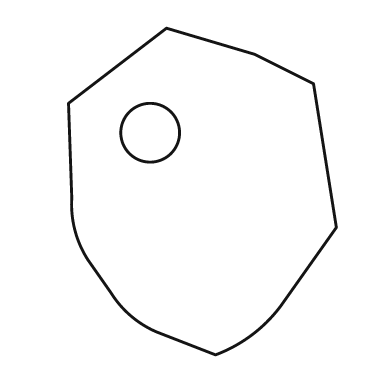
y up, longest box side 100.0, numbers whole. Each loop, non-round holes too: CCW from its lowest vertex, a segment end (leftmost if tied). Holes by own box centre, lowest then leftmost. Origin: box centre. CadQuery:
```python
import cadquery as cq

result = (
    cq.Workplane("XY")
    .moveTo(4.0, -50.0)
    .threePointArc((15.0, -44.0), (24.0, -35.0))
    .lineTo(41.0, -11.0)
    .lineTo(34.0, 33.0)
    .lineTo(16.0, 42.0)
    .lineTo(-11.0, 50.0)
    .lineTo(-41.0, 27.0)
    .lineTo(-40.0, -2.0)
    .threePointArc((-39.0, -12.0), (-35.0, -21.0))
    .lineTo(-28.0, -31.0)
    .threePointArc((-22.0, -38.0), (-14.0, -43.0))
    .close()
    .moveTo(-16.0, 18.0)
    .circle(9.0)
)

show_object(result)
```